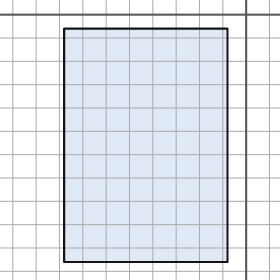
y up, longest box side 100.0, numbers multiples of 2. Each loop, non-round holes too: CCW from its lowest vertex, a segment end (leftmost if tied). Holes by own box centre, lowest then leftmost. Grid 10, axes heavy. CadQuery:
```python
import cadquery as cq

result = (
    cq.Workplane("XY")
    .moveTo(-78.0, -106.0)
    .lineTo(-8.0, -106.0)
    .lineTo(-8.0, -6.0)
    .lineTo(-78.0, -6.0)
    .close()
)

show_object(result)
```